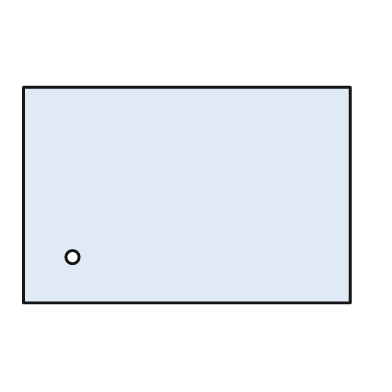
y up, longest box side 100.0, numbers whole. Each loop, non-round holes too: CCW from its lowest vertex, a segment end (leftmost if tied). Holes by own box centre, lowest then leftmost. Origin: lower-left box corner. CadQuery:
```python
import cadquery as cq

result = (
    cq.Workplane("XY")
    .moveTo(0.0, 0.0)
    .lineTo(100.0, 0.0)
    .lineTo(100.0, 66.0)
    .lineTo(0.0, 66.0)
    .close()
    .moveTo(15.0, 14.0)
    .circle(2.0)
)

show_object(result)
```